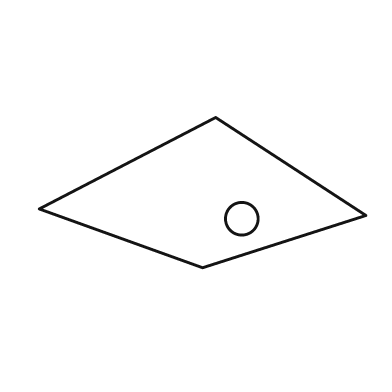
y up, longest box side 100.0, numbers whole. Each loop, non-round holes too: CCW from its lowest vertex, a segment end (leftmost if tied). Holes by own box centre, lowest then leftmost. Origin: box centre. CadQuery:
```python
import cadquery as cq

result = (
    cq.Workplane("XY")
    .moveTo(0.0, -23.0)
    .lineTo(50.0, -7.0)
    .lineTo(4.0, 23.0)
    .lineTo(-50.0, -5.0)
    .close()
    .moveTo(12.0, -8.0)
    .circle(5.0)
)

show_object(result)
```